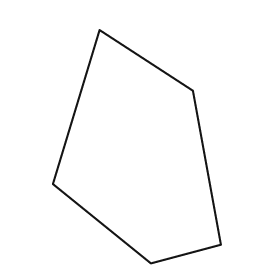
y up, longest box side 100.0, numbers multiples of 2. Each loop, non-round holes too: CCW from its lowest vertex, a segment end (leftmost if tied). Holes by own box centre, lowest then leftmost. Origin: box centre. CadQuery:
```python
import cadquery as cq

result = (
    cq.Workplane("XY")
    .moveTo(6.0, -50.0)
    .lineTo(36.0, -42.0)
    .lineTo(24.0, 24.0)
    .lineTo(-16.0, 50.0)
    .lineTo(-36.0, -16.0)
    .close()
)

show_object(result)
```